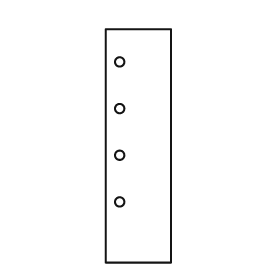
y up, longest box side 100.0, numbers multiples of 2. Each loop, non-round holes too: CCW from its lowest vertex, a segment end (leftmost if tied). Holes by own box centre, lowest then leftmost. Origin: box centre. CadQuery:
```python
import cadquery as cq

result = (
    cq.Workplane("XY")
    .moveTo(-14.0, -50.0)
    .lineTo(14.0, -50.0)
    .lineTo(14.0, 50.0)
    .lineTo(-14.0, 50.0)
    .close()
    .moveTo(-8.0, -24.0)
    .circle(2.0)
    .moveTo(-8.0, -4.0)
    .circle(2.0)
    .moveTo(-8.0, 16.0)
    .circle(2.0)
    .moveTo(-8.0, 36.0)
    .circle(2.0)
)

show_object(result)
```